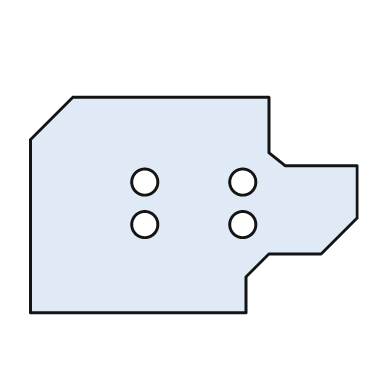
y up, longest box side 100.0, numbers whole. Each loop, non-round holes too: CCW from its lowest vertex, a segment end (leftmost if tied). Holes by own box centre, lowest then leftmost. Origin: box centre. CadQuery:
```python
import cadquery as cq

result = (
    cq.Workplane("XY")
    .moveTo(-50.0, -33.0)
    .lineTo(16.0, -33.0)
    .lineTo(16.0, -22.0)
    .lineTo(23.0, -15.0)
    .lineTo(39.0, -15.0)
    .lineTo(50.0, -4.0)
    .lineTo(50.0, 12.0)
    .lineTo(28.0, 12.0)
    .lineTo(23.0, 16.0)
    .lineTo(23.0, 33.0)
    .lineTo(-37.0, 33.0)
    .lineTo(-50.0, 20.0)
    .close()
    .moveTo(-15.0, -6.0)
    .circle(4.0)
    .moveTo(15.0, -6.0)
    .circle(4.0)
    .moveTo(-15.0, 7.0)
    .circle(4.0)
    .moveTo(15.0, 7.0)
    .circle(4.0)
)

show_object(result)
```